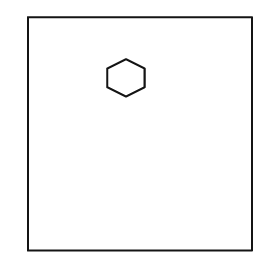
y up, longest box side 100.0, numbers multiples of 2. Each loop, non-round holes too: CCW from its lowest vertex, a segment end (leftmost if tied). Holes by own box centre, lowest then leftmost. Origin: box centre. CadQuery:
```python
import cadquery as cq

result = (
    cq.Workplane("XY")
    .moveTo(-48.0, -50.0)
    .lineTo(48.0, -50.0)
    .lineTo(48.0, 50.0)
    .lineTo(-48.0, 50.0)
    .close()
    .moveTo(-6.0, 16.0)
    .lineTo(2.0, 20.0)
    .lineTo(2.0, 28.0)
    .lineTo(-6.0, 32.0)
    .lineTo(-14.0, 28.0)
    .lineTo(-14.0, 20.0)
    .close()
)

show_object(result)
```